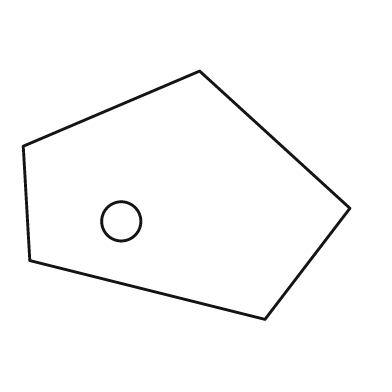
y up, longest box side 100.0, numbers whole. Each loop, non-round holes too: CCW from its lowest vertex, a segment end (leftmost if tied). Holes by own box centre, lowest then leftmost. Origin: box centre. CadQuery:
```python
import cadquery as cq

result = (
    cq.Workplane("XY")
    .moveTo(24.0, -38.0)
    .lineTo(50.0, -4.0)
    .lineTo(4.0, 38.0)
    .lineTo(-50.0, 15.0)
    .lineTo(-48.0, -20.0)
    .close()
    .moveTo(-20.0, -8.0)
    .circle(6.0)
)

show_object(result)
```